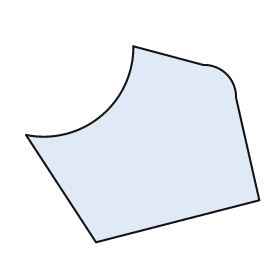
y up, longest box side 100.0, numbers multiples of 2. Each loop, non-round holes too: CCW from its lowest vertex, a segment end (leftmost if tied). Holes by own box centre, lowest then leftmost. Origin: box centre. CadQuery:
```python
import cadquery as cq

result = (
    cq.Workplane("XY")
    .moveTo(-20.0, -42.0)
    .lineTo(50.0, -24.0)
    .lineTo(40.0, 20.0)
    .threePointArc((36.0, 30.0), (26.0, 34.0))
    .lineTo(-4.0, 42.0)
    .threePointArc((-18.0, 12.0), (-50.0, 4.0))
    .close()
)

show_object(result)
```